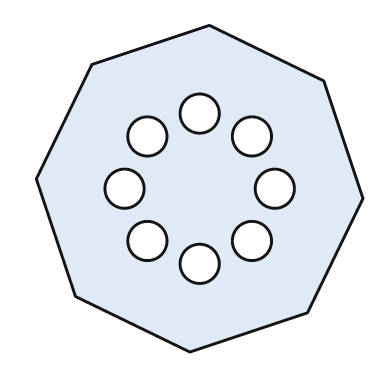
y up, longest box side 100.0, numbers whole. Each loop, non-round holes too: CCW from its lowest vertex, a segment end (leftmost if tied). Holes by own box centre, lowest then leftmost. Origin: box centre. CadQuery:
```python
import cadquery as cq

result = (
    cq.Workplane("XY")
    .moveTo(-3.0, -50.0)
    .lineTo(33.0, -38.0)
    .lineTo(50.0, -3.0)
    .lineTo(38.0, 33.0)
    .lineTo(3.0, 50.0)
    .lineTo(-33.0, 38.0)
    .lineTo(-50.0, 3.0)
    .lineTo(-38.0, -33.0)
    .close()
    .moveTo(0.0, -23.0)
    .circle(6.0)
    .moveTo(-16.0, -16.0)
    .circle(6.0)
    .moveTo(16.0, -16.0)
    .circle(6.0)
    .moveTo(-23.0, 0.0)
    .circle(6.0)
    .moveTo(23.0, 0.0)
    .circle(6.0)
    .moveTo(-16.0, 16.0)
    .circle(6.0)
    .moveTo(16.0, 16.0)
    .circle(6.0)
    .moveTo(0.0, 23.0)
    .circle(6.0)
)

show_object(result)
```